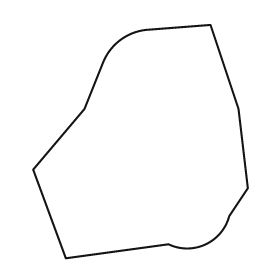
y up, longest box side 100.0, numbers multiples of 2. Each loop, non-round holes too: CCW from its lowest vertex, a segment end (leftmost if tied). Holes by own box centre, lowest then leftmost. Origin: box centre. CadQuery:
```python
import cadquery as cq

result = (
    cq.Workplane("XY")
    .moveTo(-32.0, -50.0)
    .lineTo(12.0, -44.0)
    .threePointArc((28.0, -44.0), (38.0, -32.0))
    .lineTo(46.0, -20.0)
    .lineTo(42.0, 14.0)
    .lineTo(30.0, 50.0)
    .lineTo(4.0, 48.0)
    .threePointArc((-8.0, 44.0), (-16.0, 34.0))
    .lineTo(-24.0, 14.0)
    .lineTo(-46.0, -12.0)
    .close()
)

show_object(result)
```